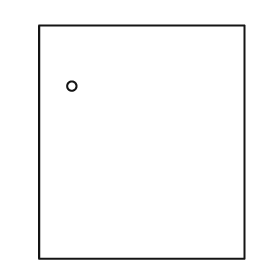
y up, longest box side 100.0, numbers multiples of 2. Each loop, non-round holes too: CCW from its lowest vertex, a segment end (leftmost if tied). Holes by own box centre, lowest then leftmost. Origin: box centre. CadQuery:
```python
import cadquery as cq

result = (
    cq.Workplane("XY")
    .moveTo(-44.0, -50.0)
    .lineTo(44.0, -50.0)
    .lineTo(44.0, 50.0)
    .lineTo(-44.0, 50.0)
    .close()
    .moveTo(-30.0, 24.0)
    .circle(2.0)
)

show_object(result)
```